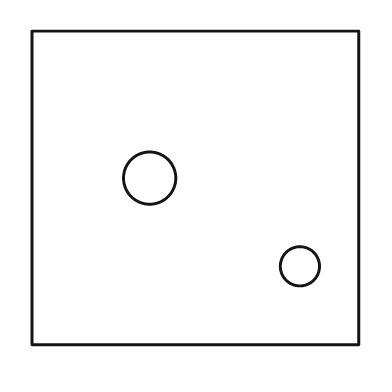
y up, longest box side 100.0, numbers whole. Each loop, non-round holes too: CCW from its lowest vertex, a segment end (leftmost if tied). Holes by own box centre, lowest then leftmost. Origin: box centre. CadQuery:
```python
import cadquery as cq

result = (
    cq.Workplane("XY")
    .moveTo(-50.0, -48.0)
    .lineTo(50.0, -48.0)
    .lineTo(50.0, 48.0)
    .lineTo(-50.0, 48.0)
    .close()
    .moveTo(32.0, -24.0)
    .circle(6.0)
    .moveTo(-14.0, 3.0)
    .circle(8.0)
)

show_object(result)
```